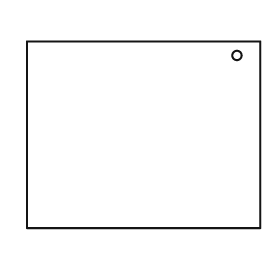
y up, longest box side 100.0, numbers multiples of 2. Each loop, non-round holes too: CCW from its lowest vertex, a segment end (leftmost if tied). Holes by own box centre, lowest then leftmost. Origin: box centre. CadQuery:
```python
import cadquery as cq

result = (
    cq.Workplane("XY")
    .moveTo(-50.0, -40.0)
    .lineTo(50.0, -40.0)
    .lineTo(50.0, 40.0)
    .lineTo(-50.0, 40.0)
    .close()
    .moveTo(40.0, 34.0)
    .circle(2.0)
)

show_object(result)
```